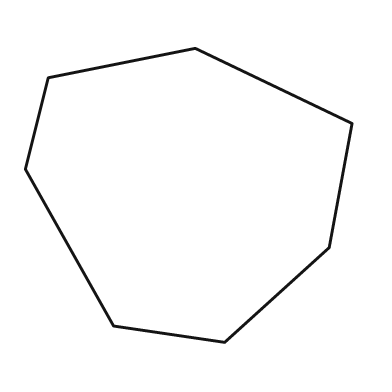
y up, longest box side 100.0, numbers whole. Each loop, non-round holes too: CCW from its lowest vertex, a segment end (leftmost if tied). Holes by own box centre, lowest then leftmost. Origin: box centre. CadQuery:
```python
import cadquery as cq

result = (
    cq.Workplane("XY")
    .moveTo(11.0, -45.0)
    .lineTo(43.0, -16.0)
    .lineTo(50.0, 22.0)
    .lineTo(2.0, 45.0)
    .lineTo(-43.0, 36.0)
    .lineTo(-50.0, 8.0)
    .lineTo(-23.0, -40.0)
    .close()
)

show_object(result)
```